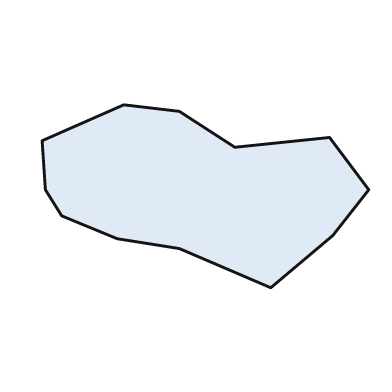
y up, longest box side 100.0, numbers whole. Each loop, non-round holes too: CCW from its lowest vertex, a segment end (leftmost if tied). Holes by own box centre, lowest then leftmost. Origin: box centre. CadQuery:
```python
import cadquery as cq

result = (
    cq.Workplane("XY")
    .moveTo(20.0, -28.0)
    .lineTo(39.0, -12.0)
    .lineTo(50.0, 2.0)
    .lineTo(38.0, 18.0)
    .lineTo(9.0, 15.0)
    .lineTo(-8.0, 26.0)
    .lineTo(-25.0, 28.0)
    .lineTo(-50.0, 17.0)
    .lineTo(-49.0, 2.0)
    .lineTo(-44.0, -6.0)
    .lineTo(-27.0, -13.0)
    .lineTo(-8.0, -16.0)
    .close()
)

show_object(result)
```